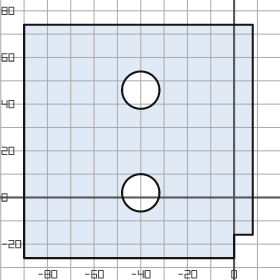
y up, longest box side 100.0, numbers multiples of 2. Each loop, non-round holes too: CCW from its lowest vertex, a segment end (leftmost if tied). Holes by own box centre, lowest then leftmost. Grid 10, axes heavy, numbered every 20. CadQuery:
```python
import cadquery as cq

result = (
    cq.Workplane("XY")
    .moveTo(-90.0, -26.0)
    .lineTo(0.0, -26.0)
    .lineTo(0.0, -16.0)
    .lineTo(8.0, -16.0)
    .lineTo(8.0, 74.0)
    .lineTo(-90.0, 74.0)
    .close()
    .moveTo(-40.0, 2.0)
    .circle(8.0)
    .moveTo(-40.0, 46.0)
    .circle(8.0)
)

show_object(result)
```